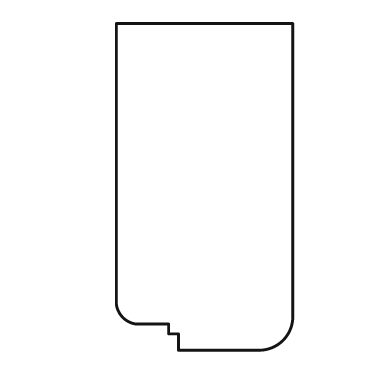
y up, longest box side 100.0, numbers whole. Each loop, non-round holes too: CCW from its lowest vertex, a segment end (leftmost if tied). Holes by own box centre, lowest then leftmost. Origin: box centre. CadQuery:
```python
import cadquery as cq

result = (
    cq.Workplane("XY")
    .moveTo(-8.0, -50.0)
    .lineTo(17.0, -50.0)
    .threePointArc((24.0, -47.0), (27.0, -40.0))
    .lineTo(27.0, 50.0)
    .lineTo(-27.0, 50.0)
    .lineTo(-27.0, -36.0)
    .threePointArc((-25.0, -40.0), (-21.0, -42.0))
    .lineTo(-11.0, -42.0)
    .lineTo(-11.0, -45.0)
    .lineTo(-8.0, -45.0)
    .close()
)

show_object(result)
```